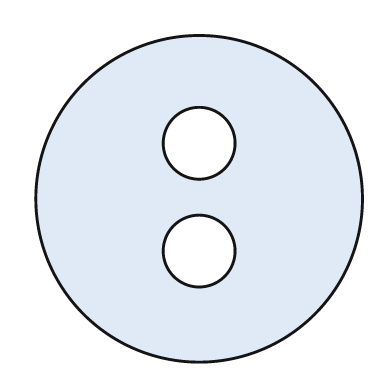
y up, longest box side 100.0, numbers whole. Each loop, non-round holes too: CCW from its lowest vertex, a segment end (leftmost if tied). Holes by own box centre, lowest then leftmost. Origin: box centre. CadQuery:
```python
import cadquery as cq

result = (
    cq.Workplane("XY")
    .moveTo(0.0, 0.0)
    .circle(50.0)
    .moveTo(0.0, -16.0)
    .circle(11.0)
    .moveTo(0.0, 17.0)
    .circle(11.0)
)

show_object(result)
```